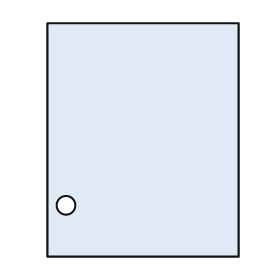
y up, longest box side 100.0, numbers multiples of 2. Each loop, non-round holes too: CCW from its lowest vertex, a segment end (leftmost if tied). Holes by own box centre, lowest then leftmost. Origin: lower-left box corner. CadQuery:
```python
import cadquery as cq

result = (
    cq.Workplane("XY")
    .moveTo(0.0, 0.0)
    .lineTo(82.0, 0.0)
    .lineTo(82.0, 100.0)
    .lineTo(0.0, 100.0)
    .close()
    .moveTo(8.0, 22.0)
    .circle(4.0)
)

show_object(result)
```